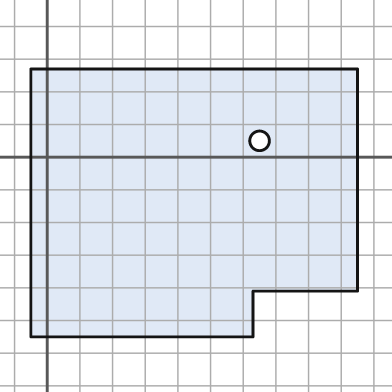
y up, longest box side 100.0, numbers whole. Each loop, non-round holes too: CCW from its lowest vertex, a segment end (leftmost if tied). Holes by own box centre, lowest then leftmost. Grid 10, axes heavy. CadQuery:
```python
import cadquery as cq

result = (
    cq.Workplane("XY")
    .moveTo(-5.0, -55.0)
    .lineTo(63.0, -55.0)
    .lineTo(63.0, -41.0)
    .lineTo(95.0, -41.0)
    .lineTo(95.0, 27.0)
    .lineTo(-5.0, 27.0)
    .close()
    .moveTo(65.0, 5.0)
    .circle(3.0)
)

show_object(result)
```